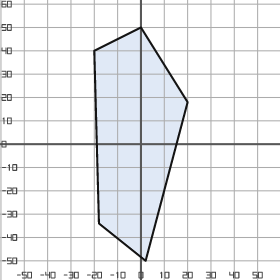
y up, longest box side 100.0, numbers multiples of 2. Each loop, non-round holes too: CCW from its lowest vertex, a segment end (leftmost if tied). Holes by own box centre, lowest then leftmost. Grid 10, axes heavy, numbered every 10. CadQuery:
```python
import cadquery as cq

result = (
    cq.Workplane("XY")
    .moveTo(2.0, -50.0)
    .lineTo(20.0, 18.0)
    .lineTo(0.0, 50.0)
    .lineTo(-20.0, 40.0)
    .lineTo(-18.0, -34.0)
    .close()
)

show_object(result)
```